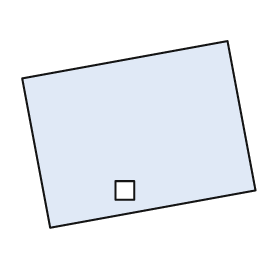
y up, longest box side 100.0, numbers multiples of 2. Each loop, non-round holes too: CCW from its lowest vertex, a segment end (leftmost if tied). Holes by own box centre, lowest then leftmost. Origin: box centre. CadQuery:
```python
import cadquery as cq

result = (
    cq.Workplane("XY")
    .moveTo(-38.0, -40.0)
    .lineTo(50.0, -24.0)
    .lineTo(38.0, 40.0)
    .lineTo(-50.0, 24.0)
    .close()
    .moveTo(-10.0, -28.0)
    .lineTo(-2.0, -28.0)
    .lineTo(-2.0, -20.0)
    .lineTo(-10.0, -20.0)
    .close()
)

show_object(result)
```